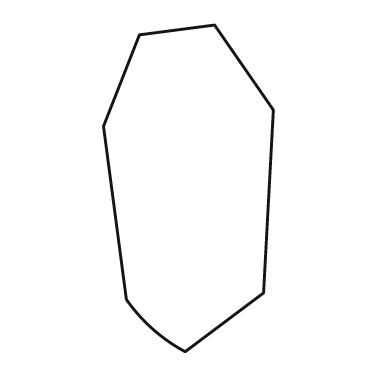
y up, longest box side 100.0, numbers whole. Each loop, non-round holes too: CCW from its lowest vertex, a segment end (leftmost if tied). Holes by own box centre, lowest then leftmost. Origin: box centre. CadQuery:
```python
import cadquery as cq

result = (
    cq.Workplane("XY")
    .moveTo(-1.0, -50.0)
    .lineTo(23.0, -32.0)
    .lineTo(26.0, 24.0)
    .lineTo(8.0, 50.0)
    .lineTo(-15.0, 47.0)
    .lineTo(-26.0, 19.0)
    .lineTo(-19.0, -34.0)
    .threePointArc((-11.0, -43.0), (-1.0, -50.0))
    .close()
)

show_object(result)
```